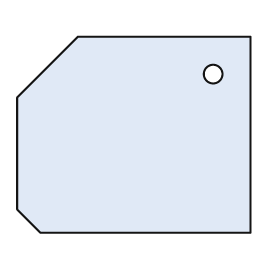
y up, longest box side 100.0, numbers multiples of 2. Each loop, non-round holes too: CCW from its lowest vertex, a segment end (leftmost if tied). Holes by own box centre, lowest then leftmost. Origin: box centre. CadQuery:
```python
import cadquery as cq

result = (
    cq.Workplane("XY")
    .moveTo(-40.0, -42.0)
    .lineTo(50.0, -42.0)
    .lineTo(50.0, 42.0)
    .lineTo(-24.0, 42.0)
    .lineTo(-50.0, 16.0)
    .lineTo(-50.0, -32.0)
    .close()
    .moveTo(34.0, 26.0)
    .circle(4.0)
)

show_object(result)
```